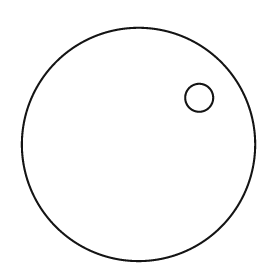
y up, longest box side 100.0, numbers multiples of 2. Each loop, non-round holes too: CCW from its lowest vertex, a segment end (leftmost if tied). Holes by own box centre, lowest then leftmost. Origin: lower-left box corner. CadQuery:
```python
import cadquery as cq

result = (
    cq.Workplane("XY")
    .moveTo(50.0, 50.0)
    .circle(50.0)
    .moveTo(76.0, 70.0)
    .circle(6.0)
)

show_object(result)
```